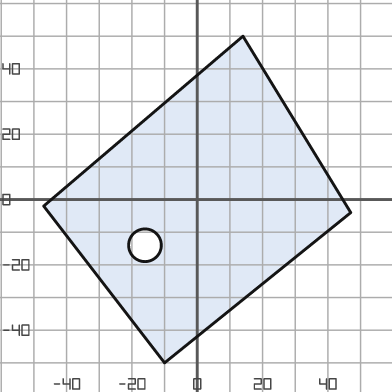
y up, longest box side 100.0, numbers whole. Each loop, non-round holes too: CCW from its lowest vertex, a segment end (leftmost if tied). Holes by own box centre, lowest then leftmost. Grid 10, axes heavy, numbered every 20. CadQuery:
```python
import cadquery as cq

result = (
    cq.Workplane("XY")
    .moveTo(-10.0, -50.0)
    .lineTo(47.0, -4.0)
    .lineTo(14.0, 50.0)
    .lineTo(-47.0, -2.0)
    .close()
    .moveTo(-16.0, -14.0)
    .circle(5.0)
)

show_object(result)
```